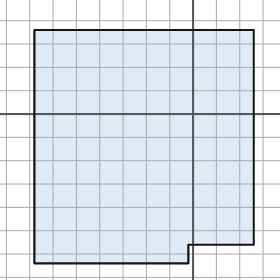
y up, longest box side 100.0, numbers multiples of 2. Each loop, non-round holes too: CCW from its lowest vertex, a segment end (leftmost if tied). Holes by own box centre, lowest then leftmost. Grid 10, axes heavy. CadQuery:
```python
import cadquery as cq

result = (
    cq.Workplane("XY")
    .moveTo(-68.0, -64.0)
    .lineTo(-2.0, -64.0)
    .lineTo(-2.0, -56.0)
    .lineTo(26.0, -56.0)
    .lineTo(26.0, 36.0)
    .lineTo(-68.0, 36.0)
    .close()
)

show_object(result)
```